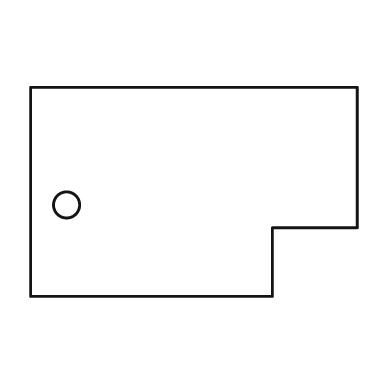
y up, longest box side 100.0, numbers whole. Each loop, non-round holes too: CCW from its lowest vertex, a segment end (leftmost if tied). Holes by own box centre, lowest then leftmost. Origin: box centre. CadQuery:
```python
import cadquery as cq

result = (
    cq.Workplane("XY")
    .moveTo(-50.0, -32.0)
    .lineTo(24.0, -32.0)
    .lineTo(24.0, -11.0)
    .lineTo(50.0, -11.0)
    .lineTo(50.0, 32.0)
    .lineTo(-50.0, 32.0)
    .close()
    .moveTo(-39.0, -4.0)
    .circle(4.0)
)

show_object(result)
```